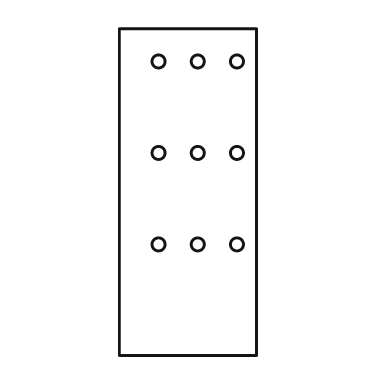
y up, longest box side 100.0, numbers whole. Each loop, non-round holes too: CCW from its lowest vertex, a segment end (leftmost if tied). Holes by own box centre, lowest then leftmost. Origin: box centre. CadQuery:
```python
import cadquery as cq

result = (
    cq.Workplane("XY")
    .moveTo(-21.0, -50.0)
    .lineTo(21.0, -50.0)
    .lineTo(21.0, 50.0)
    .lineTo(-21.0, 50.0)
    .close()
    .moveTo(-9.0, -16.0)
    .circle(2.0)
    .moveTo(3.0, -16.0)
    .circle(2.0)
    .moveTo(15.0, -16.0)
    .circle(2.0)
    .moveTo(-9.0, 12.0)
    .circle(2.0)
    .moveTo(3.0, 12.0)
    .circle(2.0)
    .moveTo(15.0, 12.0)
    .circle(2.0)
    .moveTo(-9.0, 40.0)
    .circle(2.0)
    .moveTo(3.0, 40.0)
    .circle(2.0)
    .moveTo(15.0, 40.0)
    .circle(2.0)
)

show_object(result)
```